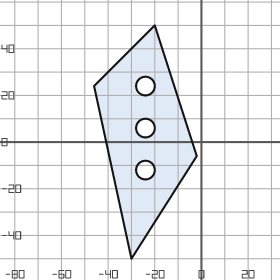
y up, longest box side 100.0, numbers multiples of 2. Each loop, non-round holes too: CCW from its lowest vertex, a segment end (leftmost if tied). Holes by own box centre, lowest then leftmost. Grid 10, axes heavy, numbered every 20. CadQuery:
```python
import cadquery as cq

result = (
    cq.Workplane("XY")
    .moveTo(-30.0, -50.0)
    .lineTo(-2.0, -6.0)
    .lineTo(-20.0, 50.0)
    .lineTo(-46.0, 24.0)
    .close()
    .moveTo(-24.0, -12.0)
    .circle(4.0)
    .moveTo(-24.0, 6.0)
    .circle(4.0)
    .moveTo(-24.0, 24.0)
    .circle(4.0)
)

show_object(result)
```